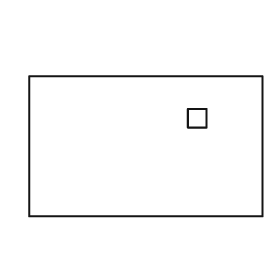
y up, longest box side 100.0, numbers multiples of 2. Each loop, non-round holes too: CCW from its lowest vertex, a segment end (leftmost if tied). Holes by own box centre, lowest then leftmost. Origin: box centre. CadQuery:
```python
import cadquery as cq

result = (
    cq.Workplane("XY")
    .moveTo(-50.0, -30.0)
    .lineTo(50.0, -30.0)
    .lineTo(50.0, 30.0)
    .lineTo(-50.0, 30.0)
    .close()
    .moveTo(18.0, 8.0)
    .lineTo(26.0, 8.0)
    .lineTo(26.0, 16.0)
    .lineTo(18.0, 16.0)
    .close()
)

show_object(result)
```